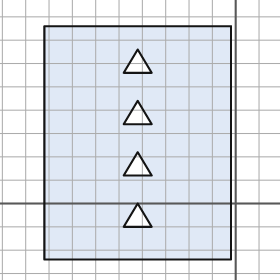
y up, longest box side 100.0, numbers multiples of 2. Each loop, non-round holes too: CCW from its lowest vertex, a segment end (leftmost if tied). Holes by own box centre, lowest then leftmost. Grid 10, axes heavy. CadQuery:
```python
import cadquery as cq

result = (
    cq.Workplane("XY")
    .moveTo(-82.0, -24.0)
    .lineTo(-2.0, -24.0)
    .lineTo(-2.0, 76.0)
    .lineTo(-82.0, 76.0)
    .close()
    .moveTo(-48.0, -10.0)
    .lineTo(-36.0, -10.0)
    .lineTo(-42.0, 0.0)
    .close()
    .moveTo(-48.0, 12.0)
    .lineTo(-36.0, 12.0)
    .lineTo(-42.0, 22.0)
    .close()
    .moveTo(-48.0, 34.0)
    .lineTo(-36.0, 34.0)
    .lineTo(-42.0, 44.0)
    .close()
    .moveTo(-48.0, 56.0)
    .lineTo(-36.0, 56.0)
    .lineTo(-42.0, 66.0)
    .close()
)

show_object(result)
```